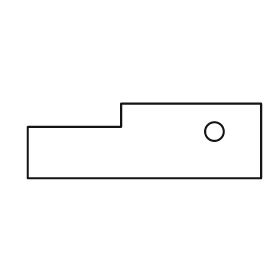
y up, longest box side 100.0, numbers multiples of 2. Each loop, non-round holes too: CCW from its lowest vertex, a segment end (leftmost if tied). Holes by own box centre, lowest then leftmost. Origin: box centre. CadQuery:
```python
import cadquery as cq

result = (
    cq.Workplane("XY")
    .moveTo(-50.0, -16.0)
    .lineTo(50.0, -16.0)
    .lineTo(50.0, 16.0)
    .lineTo(-10.0, 16.0)
    .lineTo(-10.0, 6.0)
    .lineTo(-50.0, 6.0)
    .close()
    .moveTo(30.0, 4.0)
    .circle(4.0)
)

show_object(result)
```